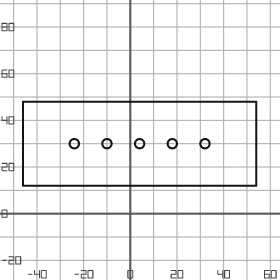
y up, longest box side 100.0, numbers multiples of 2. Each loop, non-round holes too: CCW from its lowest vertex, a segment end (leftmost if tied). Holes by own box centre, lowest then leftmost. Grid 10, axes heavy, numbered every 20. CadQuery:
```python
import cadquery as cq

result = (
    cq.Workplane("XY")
    .moveTo(-46.0, 12.0)
    .lineTo(54.0, 12.0)
    .lineTo(54.0, 48.0)
    .lineTo(-46.0, 48.0)
    .close()
    .moveTo(-24.0, 30.0)
    .circle(2.0)
    .moveTo(-10.0, 30.0)
    .circle(2.0)
    .moveTo(4.0, 30.0)
    .circle(2.0)
    .moveTo(18.0, 30.0)
    .circle(2.0)
    .moveTo(32.0, 30.0)
    .circle(2.0)
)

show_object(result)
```